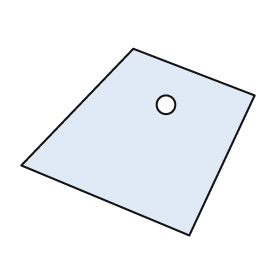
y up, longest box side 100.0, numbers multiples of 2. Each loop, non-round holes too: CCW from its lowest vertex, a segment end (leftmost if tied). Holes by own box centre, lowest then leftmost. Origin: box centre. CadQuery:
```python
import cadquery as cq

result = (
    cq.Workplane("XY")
    .moveTo(22.0, -40.0)
    .lineTo(50.0, 20.0)
    .lineTo(-2.0, 40.0)
    .lineTo(-50.0, -10.0)
    .close()
    .moveTo(12.0, 16.0)
    .circle(4.0)
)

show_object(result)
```